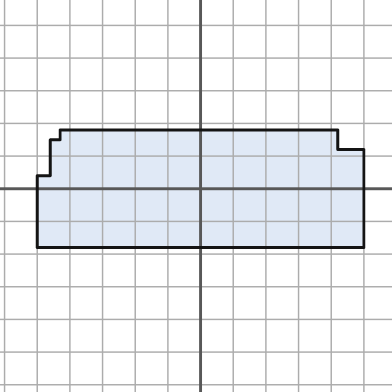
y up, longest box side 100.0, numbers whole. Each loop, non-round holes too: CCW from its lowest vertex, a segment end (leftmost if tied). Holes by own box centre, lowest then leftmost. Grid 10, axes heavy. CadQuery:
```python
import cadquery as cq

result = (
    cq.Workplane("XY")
    .moveTo(-50.0, -18.0)
    .lineTo(50.0, -18.0)
    .lineTo(50.0, 12.0)
    .lineTo(42.0, 12.0)
    .lineTo(42.0, 18.0)
    .lineTo(-43.0, 18.0)
    .lineTo(-43.0, 15.0)
    .lineTo(-46.0, 15.0)
    .lineTo(-46.0, 4.0)
    .lineTo(-50.0, 4.0)
    .close()
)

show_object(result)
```